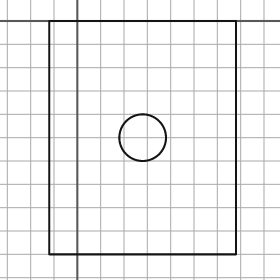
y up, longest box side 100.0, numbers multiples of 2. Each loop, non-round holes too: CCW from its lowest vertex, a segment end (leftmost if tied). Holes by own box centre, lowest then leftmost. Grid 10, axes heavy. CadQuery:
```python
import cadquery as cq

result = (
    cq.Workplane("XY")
    .moveTo(-12.0, -100.0)
    .lineTo(68.0, -100.0)
    .lineTo(68.0, 0.0)
    .lineTo(-12.0, 0.0)
    .close()
    .moveTo(28.0, -50.0)
    .circle(10.0)
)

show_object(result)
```